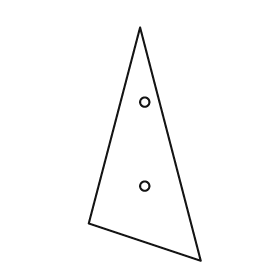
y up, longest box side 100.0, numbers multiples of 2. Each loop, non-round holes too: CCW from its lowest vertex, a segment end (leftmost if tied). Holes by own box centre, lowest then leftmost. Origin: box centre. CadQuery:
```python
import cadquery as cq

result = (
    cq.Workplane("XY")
    .moveTo(24.0, -50.0)
    .lineTo(-2.0, 50.0)
    .lineTo(-24.0, -34.0)
    .close()
    .moveTo(0.0, -18.0)
    .circle(2.0)
    .moveTo(0.0, 18.0)
    .circle(2.0)
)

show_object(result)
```